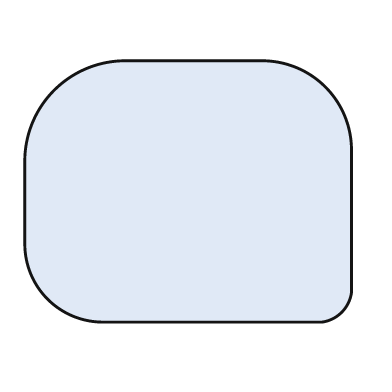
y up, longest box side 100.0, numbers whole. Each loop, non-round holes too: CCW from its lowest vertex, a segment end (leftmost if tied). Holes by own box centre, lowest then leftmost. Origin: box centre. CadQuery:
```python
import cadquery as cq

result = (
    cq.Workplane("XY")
    .moveTo(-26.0, -40.0)
    .lineTo(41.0, -40.0)
    .threePointArc((47.0, -37.0), (50.0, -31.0))
    .lineTo(50.0, 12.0)
    .threePointArc((42.0, 32.0), (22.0, 40.0))
    .lineTo(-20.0, 40.0)
    .threePointArc((-41.0, 31.0), (-50.0, 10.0))
    .lineTo(-50.0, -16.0)
    .threePointArc((-43.0, -33.0), (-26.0, -40.0))
    .close()
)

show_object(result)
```